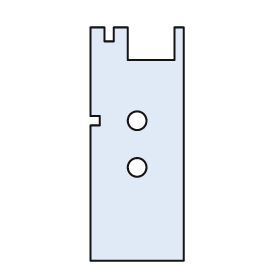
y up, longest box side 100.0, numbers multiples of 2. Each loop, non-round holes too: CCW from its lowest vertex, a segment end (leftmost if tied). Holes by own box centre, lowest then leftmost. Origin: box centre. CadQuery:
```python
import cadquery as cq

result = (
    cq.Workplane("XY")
    .moveTo(-20.0, -50.0)
    .lineTo(20.0, -50.0)
    .lineTo(20.0, 50.0)
    .lineTo(16.0, 50.0)
    .lineTo(16.0, 36.0)
    .lineTo(-4.0, 36.0)
    .lineTo(-4.0, 50.0)
    .lineTo(-10.0, 50.0)
    .lineTo(-10.0, 44.0)
    .lineTo(-14.0, 44.0)
    .lineTo(-14.0, 50.0)
    .lineTo(-20.0, 50.0)
    .lineTo(-20.0, 12.0)
    .lineTo(-16.0, 12.0)
    .lineTo(-16.0, 8.0)
    .lineTo(-20.0, 8.0)
    .close()
    .moveTo(0.0, -10.0)
    .circle(4.0)
    .moveTo(0.0, 10.0)
    .circle(4.0)
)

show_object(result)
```